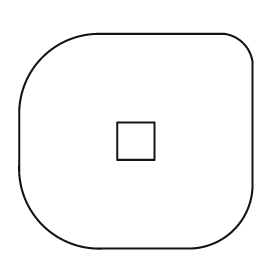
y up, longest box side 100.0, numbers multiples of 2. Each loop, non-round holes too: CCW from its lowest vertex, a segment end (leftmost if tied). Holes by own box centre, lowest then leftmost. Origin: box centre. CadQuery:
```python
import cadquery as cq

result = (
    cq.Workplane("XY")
    .moveTo(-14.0, -46.0)
    .lineTo(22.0, -46.0)
    .threePointArc((42.0, -38.0), (50.0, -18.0))
    .lineTo(50.0, 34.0)
    .threePointArc((46.0, 42.0), (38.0, 46.0))
    .lineTo(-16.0, 46.0)
    .threePointArc((-40.0, 36.0), (-50.0, 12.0))
    .lineTo(-50.0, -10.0)
    .threePointArc((-40.0, -36.0), (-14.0, -46.0))
    .close()
    .moveTo(-8.0, -8.0)
    .lineTo(8.0, -8.0)
    .lineTo(8.0, 8.0)
    .lineTo(-8.0, 8.0)
    .close()
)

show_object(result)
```